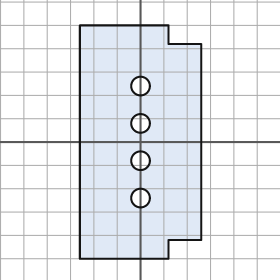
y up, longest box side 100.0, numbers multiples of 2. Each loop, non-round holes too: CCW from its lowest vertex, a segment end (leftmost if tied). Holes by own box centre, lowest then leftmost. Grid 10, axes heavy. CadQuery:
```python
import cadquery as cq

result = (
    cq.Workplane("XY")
    .moveTo(-26.0, -50.0)
    .lineTo(12.0, -50.0)
    .lineTo(12.0, -42.0)
    .lineTo(26.0, -42.0)
    .lineTo(26.0, 42.0)
    .lineTo(12.0, 42.0)
    .lineTo(12.0, 50.0)
    .lineTo(-26.0, 50.0)
    .close()
    .moveTo(0.0, -24.0)
    .circle(4.0)
    .moveTo(0.0, -8.0)
    .circle(4.0)
    .moveTo(0.0, 8.0)
    .circle(4.0)
    .moveTo(0.0, 24.0)
    .circle(4.0)
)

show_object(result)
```